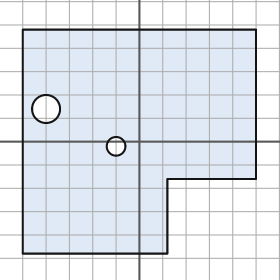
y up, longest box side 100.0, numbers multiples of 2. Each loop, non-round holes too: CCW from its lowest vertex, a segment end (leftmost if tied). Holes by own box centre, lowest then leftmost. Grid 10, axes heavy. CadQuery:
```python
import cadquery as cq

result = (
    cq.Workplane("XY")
    .moveTo(-50.0, -48.0)
    .lineTo(12.0, -48.0)
    .lineTo(12.0, -16.0)
    .lineTo(50.0, -16.0)
    .lineTo(50.0, 48.0)
    .lineTo(-50.0, 48.0)
    .close()
    .moveTo(-10.0, -2.0)
    .circle(4.0)
    .moveTo(-40.0, 14.0)
    .circle(6.0)
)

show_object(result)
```